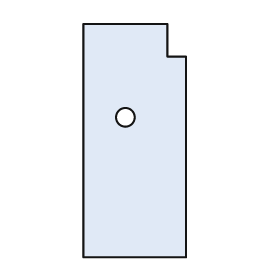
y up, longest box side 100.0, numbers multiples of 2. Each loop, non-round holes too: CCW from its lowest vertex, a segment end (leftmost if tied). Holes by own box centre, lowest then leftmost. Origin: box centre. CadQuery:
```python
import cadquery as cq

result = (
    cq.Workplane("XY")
    .moveTo(-22.0, -50.0)
    .lineTo(22.0, -50.0)
    .lineTo(22.0, 36.0)
    .lineTo(14.0, 36.0)
    .lineTo(14.0, 50.0)
    .lineTo(-22.0, 50.0)
    .close()
    .moveTo(-4.0, 10.0)
    .circle(4.0)
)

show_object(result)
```